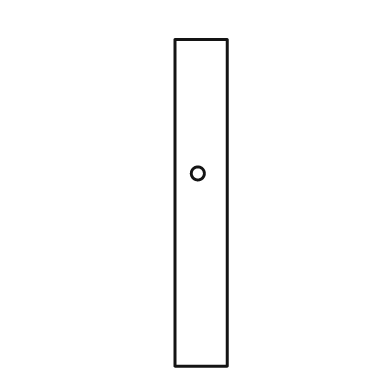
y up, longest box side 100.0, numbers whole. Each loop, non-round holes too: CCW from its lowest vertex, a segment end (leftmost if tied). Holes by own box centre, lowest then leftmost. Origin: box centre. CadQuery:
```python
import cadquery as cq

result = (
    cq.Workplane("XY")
    .moveTo(-8.0, -50.0)
    .lineTo(8.0, -50.0)
    .lineTo(8.0, 50.0)
    .lineTo(-8.0, 50.0)
    .close()
    .moveTo(-1.0, 9.0)
    .circle(2.0)
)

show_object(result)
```